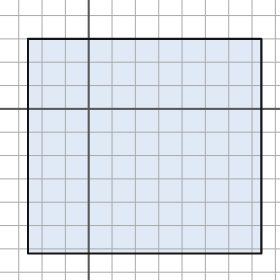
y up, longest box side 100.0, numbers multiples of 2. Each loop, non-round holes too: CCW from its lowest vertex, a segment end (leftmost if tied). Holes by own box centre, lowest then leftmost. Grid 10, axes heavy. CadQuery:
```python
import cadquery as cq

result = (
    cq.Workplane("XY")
    .moveTo(-26.0, -62.0)
    .lineTo(74.0, -62.0)
    .lineTo(74.0, 30.0)
    .lineTo(-26.0, 30.0)
    .close()
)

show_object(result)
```